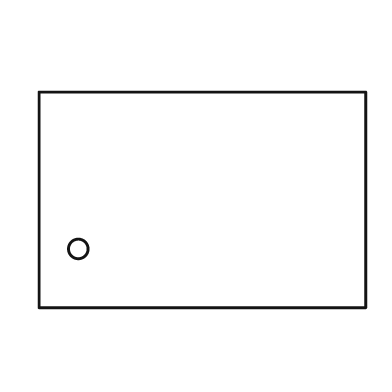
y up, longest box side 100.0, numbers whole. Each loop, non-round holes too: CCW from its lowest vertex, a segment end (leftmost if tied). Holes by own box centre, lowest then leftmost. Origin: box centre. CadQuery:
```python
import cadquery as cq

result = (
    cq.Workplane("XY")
    .moveTo(-50.0, -33.0)
    .lineTo(50.0, -33.0)
    .lineTo(50.0, 33.0)
    .lineTo(-50.0, 33.0)
    .close()
    .moveTo(-38.0, -15.0)
    .circle(3.0)
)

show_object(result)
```